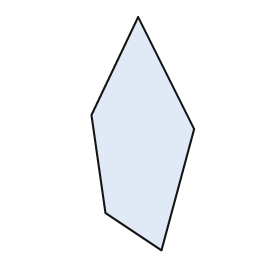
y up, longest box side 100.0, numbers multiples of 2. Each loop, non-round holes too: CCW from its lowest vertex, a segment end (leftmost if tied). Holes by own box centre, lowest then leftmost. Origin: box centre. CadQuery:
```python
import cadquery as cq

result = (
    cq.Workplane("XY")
    .moveTo(8.0, -50.0)
    .lineTo(22.0, 2.0)
    .lineTo(-2.0, 50.0)
    .lineTo(-22.0, 8.0)
    .lineTo(-16.0, -34.0)
    .close()
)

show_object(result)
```